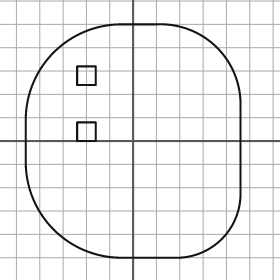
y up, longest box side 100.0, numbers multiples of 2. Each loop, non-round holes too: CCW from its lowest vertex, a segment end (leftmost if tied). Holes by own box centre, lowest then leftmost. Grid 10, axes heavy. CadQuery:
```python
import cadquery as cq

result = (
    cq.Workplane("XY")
    .moveTo(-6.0, -50.0)
    .lineTo(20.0, -50.0)
    .threePointArc((38.0, -42.0), (46.0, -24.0))
    .lineTo(46.0, 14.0)
    .threePointArc((36.0, 40.0), (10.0, 50.0))
    .lineTo(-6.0, 50.0)
    .threePointArc((-34.0, 38.0), (-46.0, 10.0))
    .lineTo(-46.0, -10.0)
    .threePointArc((-34.0, -38.0), (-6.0, -50.0))
    .close()
    .moveTo(-24.0, 0.0)
    .lineTo(-16.0, 0.0)
    .lineTo(-16.0, 8.0)
    .lineTo(-24.0, 8.0)
    .close()
    .moveTo(-24.0, 24.0)
    .lineTo(-16.0, 24.0)
    .lineTo(-16.0, 32.0)
    .lineTo(-24.0, 32.0)
    .close()
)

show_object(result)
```